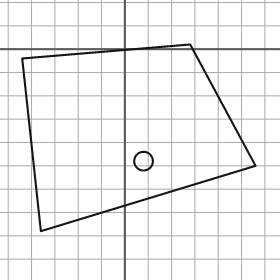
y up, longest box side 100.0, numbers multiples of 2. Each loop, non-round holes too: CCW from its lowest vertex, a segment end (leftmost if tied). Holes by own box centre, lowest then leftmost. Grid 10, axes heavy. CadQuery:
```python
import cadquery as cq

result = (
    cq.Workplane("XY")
    .moveTo(-36.0, -78.0)
    .lineTo(56.0, -50.0)
    .lineTo(28.0, 2.0)
    .lineTo(-44.0, -4.0)
    .close()
    .moveTo(8.0, -48.0)
    .circle(4.0)
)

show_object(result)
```